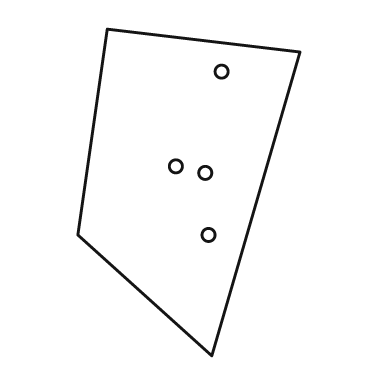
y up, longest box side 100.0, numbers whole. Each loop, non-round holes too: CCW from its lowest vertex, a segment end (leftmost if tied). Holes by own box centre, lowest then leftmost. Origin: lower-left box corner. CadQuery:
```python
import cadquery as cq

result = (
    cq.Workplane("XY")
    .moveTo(41.0, 0.0)
    .lineTo(68.0, 93.0)
    .lineTo(9.0, 100.0)
    .lineTo(0.0, 37.0)
    .close()
    .moveTo(40.0, 37.0)
    .circle(2.0)
    .moveTo(39.0, 56.0)
    .circle(2.0)
    .moveTo(30.0, 58.0)
    .circle(2.0)
    .moveTo(44.0, 87.0)
    .circle(2.0)
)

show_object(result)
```